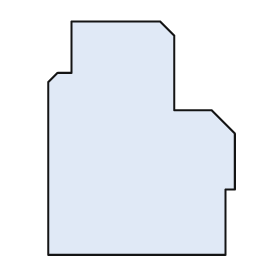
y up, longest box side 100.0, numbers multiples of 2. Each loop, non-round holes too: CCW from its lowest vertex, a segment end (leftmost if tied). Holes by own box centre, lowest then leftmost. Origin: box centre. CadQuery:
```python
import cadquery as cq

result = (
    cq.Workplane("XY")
    .moveTo(-40.0, -50.0)
    .lineTo(36.0, -50.0)
    .lineTo(36.0, -22.0)
    .lineTo(40.0, -22.0)
    .lineTo(40.0, 2.0)
    .lineTo(30.0, 12.0)
    .lineTo(14.0, 12.0)
    .lineTo(14.0, 44.0)
    .lineTo(8.0, 50.0)
    .lineTo(-30.0, 50.0)
    .lineTo(-30.0, 28.0)
    .lineTo(-36.0, 28.0)
    .lineTo(-40.0, 24.0)
    .close()
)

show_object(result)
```